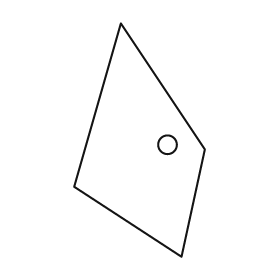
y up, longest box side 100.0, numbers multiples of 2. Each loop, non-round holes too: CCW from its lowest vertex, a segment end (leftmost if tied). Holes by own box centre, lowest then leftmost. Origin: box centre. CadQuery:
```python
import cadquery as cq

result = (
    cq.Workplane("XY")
    .moveTo(18.0, -50.0)
    .lineTo(28.0, -4.0)
    .lineTo(-8.0, 50.0)
    .lineTo(-28.0, -20.0)
    .close()
    .moveTo(12.0, -2.0)
    .circle(4.0)
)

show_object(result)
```